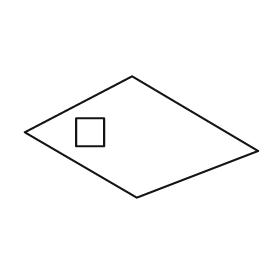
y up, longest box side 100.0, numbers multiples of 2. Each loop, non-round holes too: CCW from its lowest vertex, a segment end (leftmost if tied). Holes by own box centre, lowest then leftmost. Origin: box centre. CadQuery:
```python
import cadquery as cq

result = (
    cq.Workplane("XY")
    .moveTo(-2.0, -26.0)
    .lineTo(50.0, -6.0)
    .lineTo(-4.0, 26.0)
    .lineTo(-50.0, 2.0)
    .close()
    .moveTo(-28.0, -4.0)
    .lineTo(-16.0, -4.0)
    .lineTo(-16.0, 8.0)
    .lineTo(-28.0, 8.0)
    .close()
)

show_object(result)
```